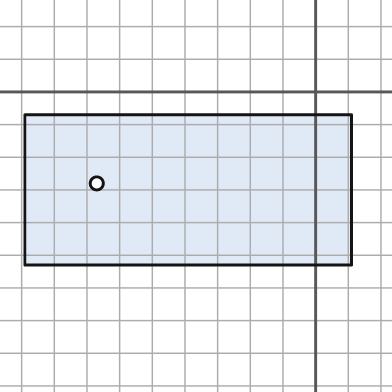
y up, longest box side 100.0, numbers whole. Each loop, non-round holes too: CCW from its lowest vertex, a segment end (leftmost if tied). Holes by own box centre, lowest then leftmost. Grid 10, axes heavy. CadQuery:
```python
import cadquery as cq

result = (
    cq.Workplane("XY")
    .moveTo(-89.0, -53.0)
    .lineTo(11.0, -53.0)
    .lineTo(11.0, -7.0)
    .lineTo(-89.0, -7.0)
    .close()
    .moveTo(-67.0, -28.0)
    .circle(2.0)
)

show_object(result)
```